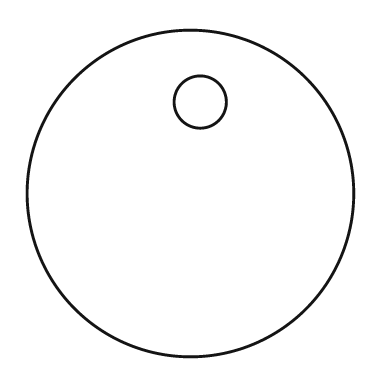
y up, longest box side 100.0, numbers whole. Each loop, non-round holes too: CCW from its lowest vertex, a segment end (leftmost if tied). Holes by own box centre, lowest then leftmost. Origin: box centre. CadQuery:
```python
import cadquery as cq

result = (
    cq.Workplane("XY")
    .moveTo(0.0, 0.0)
    .circle(50.0)
    .moveTo(3.0, 28.0)
    .circle(8.0)
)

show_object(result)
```